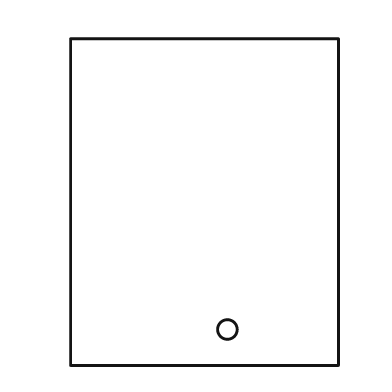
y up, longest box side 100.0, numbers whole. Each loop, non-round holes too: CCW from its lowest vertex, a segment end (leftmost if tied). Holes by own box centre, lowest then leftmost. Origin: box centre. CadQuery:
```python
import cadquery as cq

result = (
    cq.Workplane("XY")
    .moveTo(-41.0, -50.0)
    .lineTo(41.0, -50.0)
    .lineTo(41.0, 50.0)
    .lineTo(-41.0, 50.0)
    .close()
    .moveTo(7.0, -39.0)
    .circle(3.0)
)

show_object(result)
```